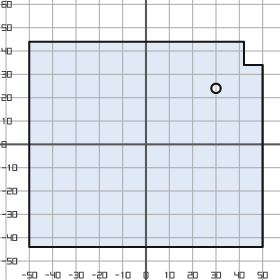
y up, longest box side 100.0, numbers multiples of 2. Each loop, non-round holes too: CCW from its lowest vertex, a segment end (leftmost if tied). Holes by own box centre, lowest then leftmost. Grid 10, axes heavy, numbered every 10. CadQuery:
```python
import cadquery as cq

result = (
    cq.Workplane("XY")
    .moveTo(-50.0, -44.0)
    .lineTo(50.0, -44.0)
    .lineTo(50.0, 34.0)
    .lineTo(42.0, 34.0)
    .lineTo(42.0, 44.0)
    .lineTo(-50.0, 44.0)
    .close()
    .moveTo(30.0, 24.0)
    .circle(2.0)
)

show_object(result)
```